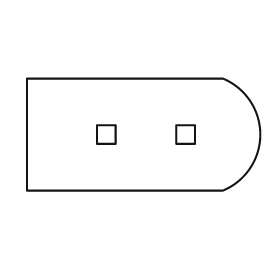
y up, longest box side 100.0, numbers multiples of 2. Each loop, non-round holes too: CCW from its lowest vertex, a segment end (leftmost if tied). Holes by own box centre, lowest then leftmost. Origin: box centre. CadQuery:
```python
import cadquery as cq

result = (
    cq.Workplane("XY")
    .moveTo(-50.0, -24.0)
    .lineTo(34.0, -24.0)
    .threePointArc((50.0, 0.0), (34.0, 24.0))
    .lineTo(-50.0, 24.0)
    .close()
    .moveTo(-20.0, -4.0)
    .lineTo(-12.0, -4.0)
    .lineTo(-12.0, 4.0)
    .lineTo(-20.0, 4.0)
    .close()
    .moveTo(14.0, -4.0)
    .lineTo(22.0, -4.0)
    .lineTo(22.0, 4.0)
    .lineTo(14.0, 4.0)
    .close()
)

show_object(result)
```